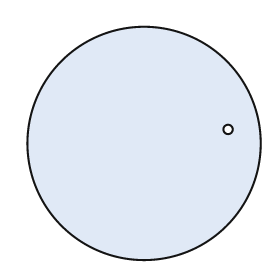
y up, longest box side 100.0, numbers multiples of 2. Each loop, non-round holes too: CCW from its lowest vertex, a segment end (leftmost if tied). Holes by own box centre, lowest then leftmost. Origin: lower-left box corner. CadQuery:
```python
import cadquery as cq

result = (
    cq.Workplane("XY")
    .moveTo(50.0, 50.0)
    .circle(50.0)
    .moveTo(86.0, 56.0)
    .circle(2.0)
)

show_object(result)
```